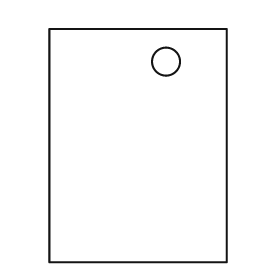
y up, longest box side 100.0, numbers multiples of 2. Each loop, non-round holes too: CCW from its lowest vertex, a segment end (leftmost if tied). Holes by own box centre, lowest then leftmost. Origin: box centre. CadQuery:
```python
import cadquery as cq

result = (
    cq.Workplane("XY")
    .moveTo(-38.0, -50.0)
    .lineTo(38.0, -50.0)
    .lineTo(38.0, 50.0)
    .lineTo(-38.0, 50.0)
    .close()
    .moveTo(12.0, 36.0)
    .circle(6.0)
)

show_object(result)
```